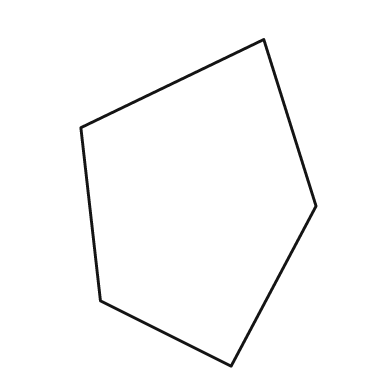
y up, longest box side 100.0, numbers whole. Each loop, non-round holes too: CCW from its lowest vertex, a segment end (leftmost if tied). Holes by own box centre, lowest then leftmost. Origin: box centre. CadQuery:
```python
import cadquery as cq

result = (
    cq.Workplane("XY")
    .moveTo(10.0, -50.0)
    .lineTo(36.0, -1.0)
    .lineTo(20.0, 50.0)
    .lineTo(-36.0, 23.0)
    .lineTo(-30.0, -30.0)
    .close()
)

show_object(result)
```